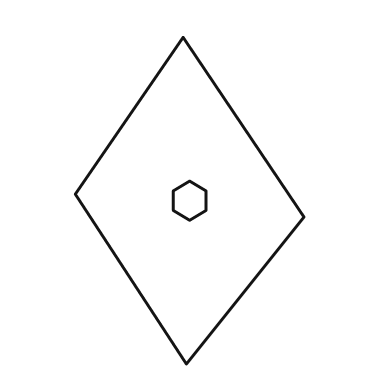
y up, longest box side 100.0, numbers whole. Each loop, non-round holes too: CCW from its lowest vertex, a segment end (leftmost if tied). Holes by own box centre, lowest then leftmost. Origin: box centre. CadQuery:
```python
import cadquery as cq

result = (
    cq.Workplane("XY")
    .moveTo(-1.0, -50.0)
    .lineTo(35.0, -5.0)
    .lineTo(-2.0, 50.0)
    .lineTo(-35.0, 2.0)
    .close()
    .moveTo(0.0, -6.0)
    .lineTo(5.0, -3.0)
    .lineTo(5.0, 3.0)
    .lineTo(0.0, 6.0)
    .lineTo(-5.0, 3.0)
    .lineTo(-5.0, -3.0)
    .close()
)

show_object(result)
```